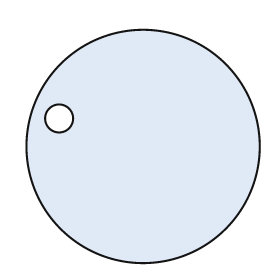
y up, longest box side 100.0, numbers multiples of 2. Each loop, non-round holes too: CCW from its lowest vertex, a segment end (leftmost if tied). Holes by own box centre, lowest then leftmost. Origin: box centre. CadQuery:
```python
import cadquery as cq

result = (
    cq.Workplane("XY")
    .moveTo(0.0, 0.0)
    .circle(50.0)
    .moveTo(-36.0, 12.0)
    .circle(6.0)
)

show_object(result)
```